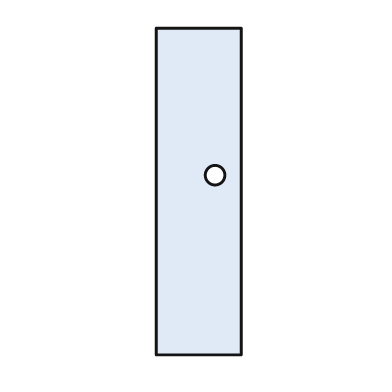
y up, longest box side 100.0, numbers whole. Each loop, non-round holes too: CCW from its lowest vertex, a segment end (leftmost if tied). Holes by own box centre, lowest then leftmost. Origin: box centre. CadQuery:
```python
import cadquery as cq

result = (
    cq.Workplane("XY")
    .moveTo(-13.0, -50.0)
    .lineTo(13.0, -50.0)
    .lineTo(13.0, 50.0)
    .lineTo(-13.0, 50.0)
    .close()
    .moveTo(5.0, 5.0)
    .circle(3.0)
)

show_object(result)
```